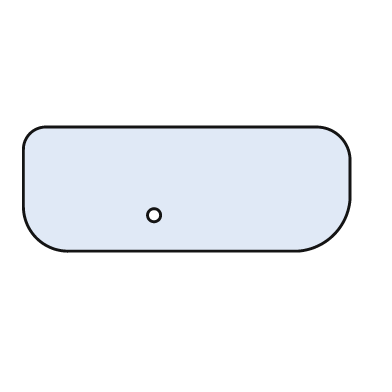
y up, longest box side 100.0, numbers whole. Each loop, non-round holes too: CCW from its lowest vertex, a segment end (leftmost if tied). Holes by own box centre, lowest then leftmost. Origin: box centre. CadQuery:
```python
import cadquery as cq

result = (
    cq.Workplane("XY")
    .moveTo(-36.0, -19.0)
    .lineTo(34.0, -19.0)
    .threePointArc((45.0, -14.0), (50.0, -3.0))
    .lineTo(50.0, 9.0)
    .threePointArc((47.0, 16.0), (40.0, 19.0))
    .lineTo(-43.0, 19.0)
    .threePointArc((-48.0, 17.0), (-50.0, 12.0))
    .lineTo(-50.0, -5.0)
    .threePointArc((-46.0, -15.0), (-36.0, -19.0))
    .close()
    .moveTo(-10.0, -8.0)
    .circle(2.0)
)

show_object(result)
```